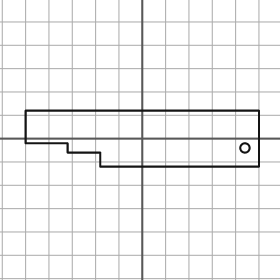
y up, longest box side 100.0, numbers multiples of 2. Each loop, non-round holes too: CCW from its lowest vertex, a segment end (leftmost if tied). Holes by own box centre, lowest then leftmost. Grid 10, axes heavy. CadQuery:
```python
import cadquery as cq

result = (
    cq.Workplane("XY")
    .moveTo(-18.0, -12.0)
    .lineTo(50.0, -12.0)
    .lineTo(50.0, 12.0)
    .lineTo(-50.0, 12.0)
    .lineTo(-50.0, -2.0)
    .lineTo(-32.0, -2.0)
    .lineTo(-32.0, -6.0)
    .lineTo(-18.0, -6.0)
    .close()
    .moveTo(44.0, -4.0)
    .circle(2.0)
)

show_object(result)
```